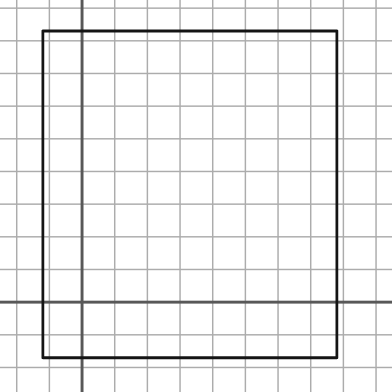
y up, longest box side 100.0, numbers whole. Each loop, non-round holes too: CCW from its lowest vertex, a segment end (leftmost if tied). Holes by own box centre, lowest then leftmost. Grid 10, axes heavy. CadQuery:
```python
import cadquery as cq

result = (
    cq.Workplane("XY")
    .moveTo(-12.0, -17.0)
    .lineTo(78.0, -17.0)
    .lineTo(78.0, 83.0)
    .lineTo(-12.0, 83.0)
    .close()
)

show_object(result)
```